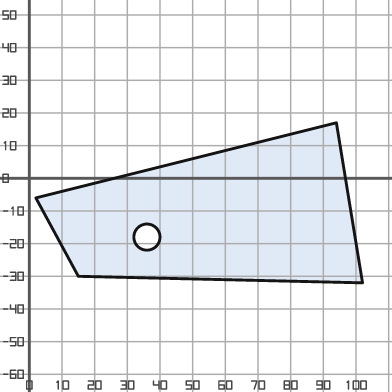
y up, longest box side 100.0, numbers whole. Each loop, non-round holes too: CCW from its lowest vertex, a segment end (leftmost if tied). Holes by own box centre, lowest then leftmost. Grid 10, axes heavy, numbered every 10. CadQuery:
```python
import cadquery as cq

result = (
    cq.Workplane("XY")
    .moveTo(102.0, -32.0)
    .lineTo(94.0, 17.0)
    .lineTo(2.0, -6.0)
    .lineTo(15.0, -30.0)
    .close()
    .moveTo(36.0, -18.0)
    .circle(4.0)
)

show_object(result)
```